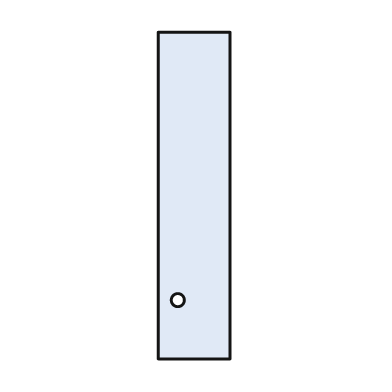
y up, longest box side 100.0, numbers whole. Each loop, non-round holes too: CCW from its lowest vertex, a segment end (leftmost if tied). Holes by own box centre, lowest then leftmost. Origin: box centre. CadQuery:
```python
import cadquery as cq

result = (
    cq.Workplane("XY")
    .moveTo(-11.0, -50.0)
    .lineTo(11.0, -50.0)
    .lineTo(11.0, 50.0)
    .lineTo(-11.0, 50.0)
    .close()
    .moveTo(-5.0, -32.0)
    .circle(2.0)
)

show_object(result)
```